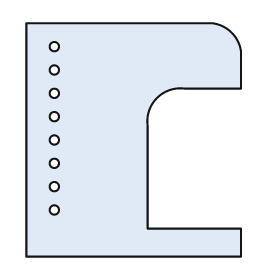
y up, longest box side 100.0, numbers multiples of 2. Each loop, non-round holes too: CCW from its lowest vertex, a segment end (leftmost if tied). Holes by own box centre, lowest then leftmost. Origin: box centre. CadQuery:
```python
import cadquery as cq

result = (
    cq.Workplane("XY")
    .moveTo(-46.0, -50.0)
    .lineTo(46.0, -50.0)
    .lineTo(46.0, -38.0)
    .lineTo(6.0, -38.0)
    .lineTo(6.0, 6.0)
    .threePointArc((10.0, 18.0), (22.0, 22.0))
    .lineTo(46.0, 22.0)
    .lineTo(46.0, 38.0)
    .threePointArc((42.0, 46.0), (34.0, 50.0))
    .lineTo(-46.0, 50.0)
    .close()
    .moveTo(-34.0, -30.0)
    .circle(2.0)
    .moveTo(-34.0, -20.0)
    .circle(2.0)
    .moveTo(-34.0, -10.0)
    .circle(2.0)
    .moveTo(-34.0, 0.0)
    .circle(2.0)
    .moveTo(-34.0, 10.0)
    .circle(2.0)
    .moveTo(-34.0, 20.0)
    .circle(2.0)
    .moveTo(-34.0, 30.0)
    .circle(2.0)
    .moveTo(-34.0, 40.0)
    .circle(2.0)
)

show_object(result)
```